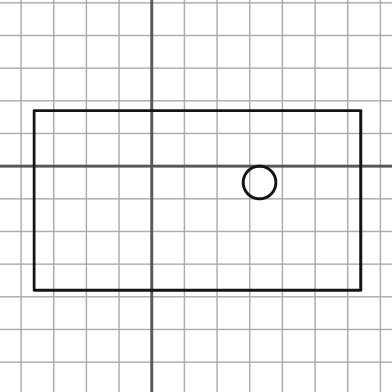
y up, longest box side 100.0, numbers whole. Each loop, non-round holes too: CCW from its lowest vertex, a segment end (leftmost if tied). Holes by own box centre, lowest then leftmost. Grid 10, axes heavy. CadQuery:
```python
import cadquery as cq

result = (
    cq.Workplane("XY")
    .moveTo(-36.0, -38.0)
    .lineTo(64.0, -38.0)
    .lineTo(64.0, 17.0)
    .lineTo(-36.0, 17.0)
    .close()
    .moveTo(33.0, -5.0)
    .circle(5.0)
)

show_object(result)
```